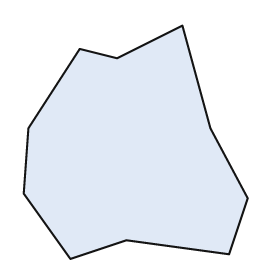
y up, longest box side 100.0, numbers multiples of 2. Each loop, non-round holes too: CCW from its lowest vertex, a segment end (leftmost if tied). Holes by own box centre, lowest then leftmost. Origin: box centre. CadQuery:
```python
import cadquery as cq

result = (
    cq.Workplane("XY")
    .moveTo(-28.0, -50.0)
    .lineTo(-4.0, -42.0)
    .lineTo(40.0, -48.0)
    .lineTo(48.0, -24.0)
    .lineTo(32.0, 6.0)
    .lineTo(20.0, 50.0)
    .lineTo(-8.0, 36.0)
    .lineTo(-24.0, 40.0)
    .lineTo(-46.0, 6.0)
    .lineTo(-48.0, -22.0)
    .close()
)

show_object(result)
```